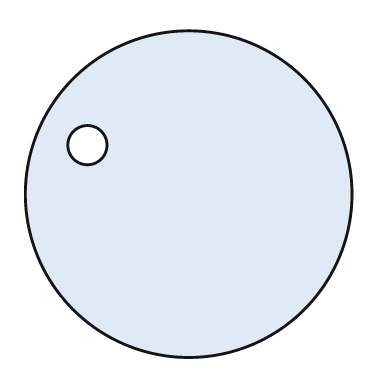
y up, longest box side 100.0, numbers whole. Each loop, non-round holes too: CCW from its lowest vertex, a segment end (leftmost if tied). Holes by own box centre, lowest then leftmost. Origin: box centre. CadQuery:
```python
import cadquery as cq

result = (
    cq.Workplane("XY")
    .moveTo(0.0, 0.0)
    .circle(50.0)
    .moveTo(-31.0, 15.0)
    .circle(6.0)
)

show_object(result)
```